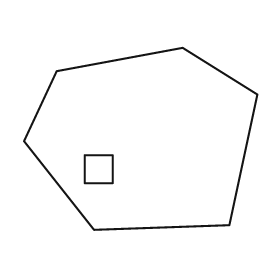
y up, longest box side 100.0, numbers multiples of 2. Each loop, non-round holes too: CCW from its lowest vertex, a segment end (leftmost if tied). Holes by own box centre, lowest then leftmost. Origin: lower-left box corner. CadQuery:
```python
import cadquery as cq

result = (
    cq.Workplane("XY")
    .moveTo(30.0, 0.0)
    .lineTo(88.0, 2.0)
    .lineTo(100.0, 58.0)
    .lineTo(68.0, 78.0)
    .lineTo(14.0, 68.0)
    .lineTo(0.0, 38.0)
    .close()
    .moveTo(26.0, 20.0)
    .lineTo(38.0, 20.0)
    .lineTo(38.0, 32.0)
    .lineTo(26.0, 32.0)
    .close()
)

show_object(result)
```